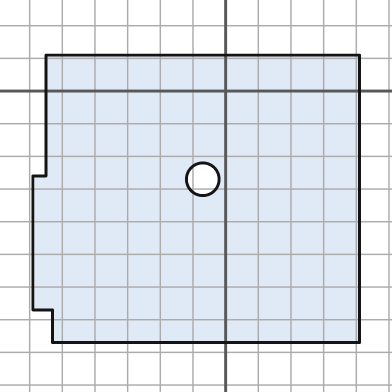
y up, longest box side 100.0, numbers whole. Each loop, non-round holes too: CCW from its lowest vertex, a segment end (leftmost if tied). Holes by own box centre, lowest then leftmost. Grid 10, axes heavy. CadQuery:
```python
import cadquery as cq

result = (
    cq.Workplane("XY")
    .moveTo(-53.0, -77.0)
    .lineTo(41.0, -77.0)
    .lineTo(41.0, 11.0)
    .lineTo(-55.0, 11.0)
    .lineTo(-55.0, -26.0)
    .lineTo(-59.0, -26.0)
    .lineTo(-59.0, -67.0)
    .lineTo(-53.0, -67.0)
    .close()
    .moveTo(-7.0, -27.0)
    .circle(5.0)
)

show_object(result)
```